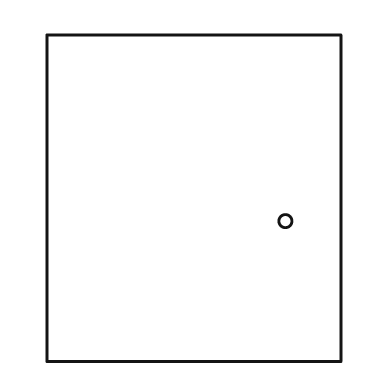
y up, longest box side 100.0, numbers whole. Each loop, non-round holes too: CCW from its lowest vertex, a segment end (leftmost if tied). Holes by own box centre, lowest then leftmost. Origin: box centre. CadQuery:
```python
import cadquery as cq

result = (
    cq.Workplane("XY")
    .moveTo(-45.0, -50.0)
    .lineTo(45.0, -50.0)
    .lineTo(45.0, 50.0)
    .lineTo(-45.0, 50.0)
    .close()
    .moveTo(28.0, -7.0)
    .circle(2.0)
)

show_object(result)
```